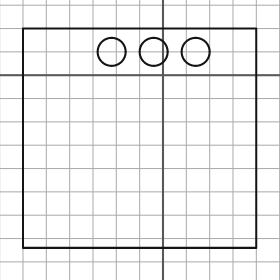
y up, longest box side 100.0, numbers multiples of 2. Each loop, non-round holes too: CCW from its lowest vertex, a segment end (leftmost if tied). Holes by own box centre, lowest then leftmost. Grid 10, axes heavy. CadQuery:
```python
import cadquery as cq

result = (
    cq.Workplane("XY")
    .moveTo(-60.0, -74.0)
    .lineTo(40.0, -74.0)
    .lineTo(40.0, 20.0)
    .lineTo(-60.0, 20.0)
    .close()
    .moveTo(-22.0, 10.0)
    .circle(6.0)
    .moveTo(-4.0, 10.0)
    .circle(6.0)
    .moveTo(14.0, 10.0)
    .circle(6.0)
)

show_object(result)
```